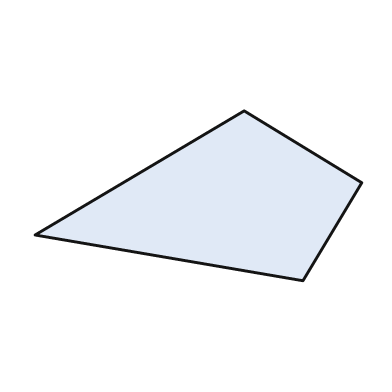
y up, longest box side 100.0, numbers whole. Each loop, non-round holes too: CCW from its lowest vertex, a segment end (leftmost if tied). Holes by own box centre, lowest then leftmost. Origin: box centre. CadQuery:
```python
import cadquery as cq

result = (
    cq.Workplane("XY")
    .moveTo(32.0, -26.0)
    .lineTo(50.0, 4.0)
    .lineTo(14.0, 26.0)
    .lineTo(-50.0, -12.0)
    .close()
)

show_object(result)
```